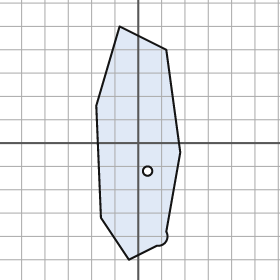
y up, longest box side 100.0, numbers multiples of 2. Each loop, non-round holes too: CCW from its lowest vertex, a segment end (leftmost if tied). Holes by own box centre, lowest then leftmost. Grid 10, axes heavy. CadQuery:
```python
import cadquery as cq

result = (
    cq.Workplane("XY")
    .moveTo(-4.0, -50.0)
    .lineTo(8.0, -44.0)
    .threePointArc((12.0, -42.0), (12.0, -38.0))
    .lineTo(18.0, -4.0)
    .lineTo(12.0, 40.0)
    .lineTo(-8.0, 50.0)
    .lineTo(-18.0, 16.0)
    .lineTo(-16.0, -32.0)
    .close()
    .moveTo(4.0, -12.0)
    .circle(2.0)
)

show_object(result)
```